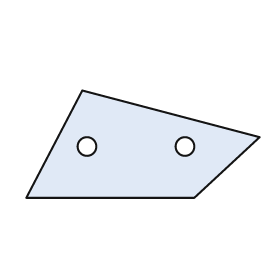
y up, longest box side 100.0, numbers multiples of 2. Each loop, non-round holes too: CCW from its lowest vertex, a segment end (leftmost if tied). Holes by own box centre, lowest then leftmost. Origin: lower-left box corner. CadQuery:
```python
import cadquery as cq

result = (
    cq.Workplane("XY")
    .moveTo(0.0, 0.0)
    .lineTo(72.0, 0.0)
    .lineTo(100.0, 26.0)
    .lineTo(24.0, 46.0)
    .close()
    .moveTo(26.0, 22.0)
    .circle(4.0)
    .moveTo(68.0, 22.0)
    .circle(4.0)
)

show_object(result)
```